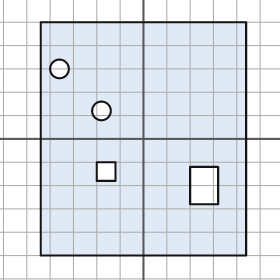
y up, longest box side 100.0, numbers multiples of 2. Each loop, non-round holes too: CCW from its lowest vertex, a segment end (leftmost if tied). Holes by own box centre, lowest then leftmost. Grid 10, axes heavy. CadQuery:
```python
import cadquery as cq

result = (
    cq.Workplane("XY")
    .moveTo(-44.0, -50.0)
    .lineTo(44.0, -50.0)
    .lineTo(44.0, 50.0)
    .lineTo(-44.0, 50.0)
    .close()
    .moveTo(20.0, -28.0)
    .lineTo(32.0, -28.0)
    .lineTo(32.0, -12.0)
    .lineTo(20.0, -12.0)
    .close()
    .moveTo(-20.0, -18.0)
    .lineTo(-12.0, -18.0)
    .lineTo(-12.0, -10.0)
    .lineTo(-20.0, -10.0)
    .close()
    .moveTo(-18.0, 12.0)
    .circle(4.0)
    .moveTo(-36.0, 30.0)
    .circle(4.0)
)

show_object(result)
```